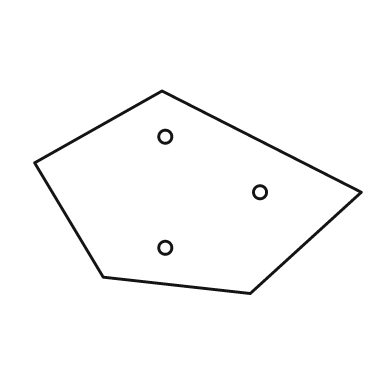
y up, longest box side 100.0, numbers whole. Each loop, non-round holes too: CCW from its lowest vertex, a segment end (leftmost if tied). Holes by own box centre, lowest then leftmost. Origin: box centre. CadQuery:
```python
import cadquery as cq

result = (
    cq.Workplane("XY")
    .moveTo(16.0, -31.0)
    .lineTo(50.0, 0.0)
    .lineTo(-11.0, 31.0)
    .lineTo(-50.0, 9.0)
    .lineTo(-29.0, -26.0)
    .close()
    .moveTo(-10.0, -17.0)
    .circle(2.0)
    .moveTo(19.0, 0.0)
    .circle(2.0)
    .moveTo(-10.0, 17.0)
    .circle(2.0)
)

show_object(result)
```